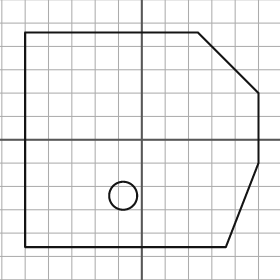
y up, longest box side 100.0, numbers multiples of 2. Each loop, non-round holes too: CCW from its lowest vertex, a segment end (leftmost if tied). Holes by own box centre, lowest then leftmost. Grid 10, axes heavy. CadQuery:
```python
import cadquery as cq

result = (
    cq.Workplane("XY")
    .moveTo(-50.0, -46.0)
    .lineTo(36.0, -46.0)
    .lineTo(50.0, -10.0)
    .lineTo(50.0, 20.0)
    .lineTo(24.0, 46.0)
    .lineTo(-50.0, 46.0)
    .close()
    .moveTo(-8.0, -24.0)
    .circle(6.0)
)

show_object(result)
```